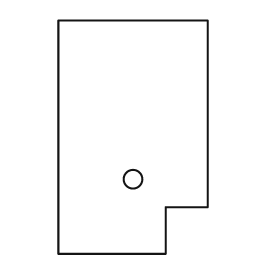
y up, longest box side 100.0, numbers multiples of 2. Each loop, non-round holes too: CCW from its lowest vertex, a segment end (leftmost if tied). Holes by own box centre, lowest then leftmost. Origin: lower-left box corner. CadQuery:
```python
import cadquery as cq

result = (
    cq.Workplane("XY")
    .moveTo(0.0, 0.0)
    .lineTo(46.0, 0.0)
    .lineTo(46.0, 20.0)
    .lineTo(64.0, 20.0)
    .lineTo(64.0, 100.0)
    .lineTo(0.0, 100.0)
    .close()
    .moveTo(32.0, 32.0)
    .circle(4.0)
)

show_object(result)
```